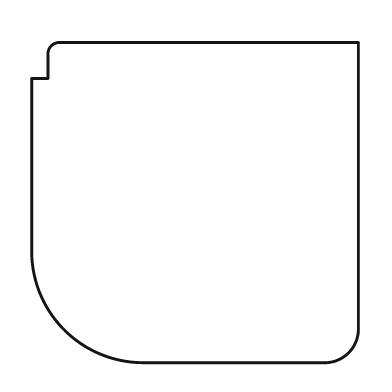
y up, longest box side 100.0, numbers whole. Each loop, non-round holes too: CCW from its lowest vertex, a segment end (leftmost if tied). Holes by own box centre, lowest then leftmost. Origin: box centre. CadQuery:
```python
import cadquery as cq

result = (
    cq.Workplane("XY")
    .moveTo(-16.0, -49.0)
    .lineTo(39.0, -49.0)
    .threePointArc((47.0, -46.0), (50.0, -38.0))
    .lineTo(50.0, 49.0)
    .lineTo(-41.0, 49.0)
    .threePointArc((-44.0, 48.0), (-45.0, 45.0))
    .lineTo(-45.0, 38.0)
    .lineTo(-50.0, 38.0)
    .lineTo(-50.0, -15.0)
    .threePointArc((-40.0, -39.0), (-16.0, -49.0))
    .close()
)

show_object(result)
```